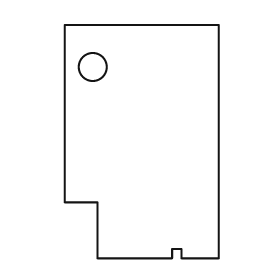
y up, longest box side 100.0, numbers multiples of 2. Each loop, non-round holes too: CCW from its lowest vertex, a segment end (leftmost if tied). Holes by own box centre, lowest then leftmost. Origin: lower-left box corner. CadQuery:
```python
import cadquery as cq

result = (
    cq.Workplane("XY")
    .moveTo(14.0, 0.0)
    .lineTo(46.0, 0.0)
    .lineTo(46.0, 4.0)
    .lineTo(50.0, 4.0)
    .lineTo(50.0, 0.0)
    .lineTo(66.0, 0.0)
    .lineTo(66.0, 100.0)
    .lineTo(0.0, 100.0)
    .lineTo(0.0, 24.0)
    .lineTo(14.0, 24.0)
    .close()
    .moveTo(12.0, 82.0)
    .circle(6.0)
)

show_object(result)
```